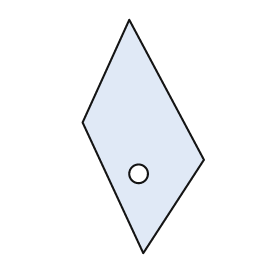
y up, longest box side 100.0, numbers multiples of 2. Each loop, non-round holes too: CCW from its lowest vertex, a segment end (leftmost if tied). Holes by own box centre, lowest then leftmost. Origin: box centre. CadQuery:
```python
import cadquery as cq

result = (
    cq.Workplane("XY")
    .moveTo(0.0, -50.0)
    .lineTo(26.0, -10.0)
    .lineTo(-6.0, 50.0)
    .lineTo(-26.0, 6.0)
    .close()
    .moveTo(-2.0, -16.0)
    .circle(4.0)
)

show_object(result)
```